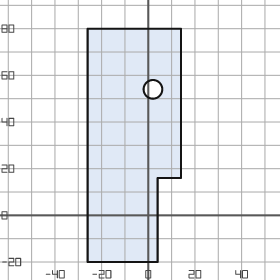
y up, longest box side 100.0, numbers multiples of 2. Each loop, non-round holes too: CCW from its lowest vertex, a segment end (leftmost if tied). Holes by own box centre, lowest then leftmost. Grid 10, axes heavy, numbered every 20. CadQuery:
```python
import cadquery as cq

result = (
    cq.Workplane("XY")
    .moveTo(-26.0, -20.0)
    .lineTo(4.0, -20.0)
    .lineTo(4.0, 16.0)
    .lineTo(14.0, 16.0)
    .lineTo(14.0, 80.0)
    .lineTo(-26.0, 80.0)
    .close()
    .moveTo(2.0, 54.0)
    .circle(4.0)
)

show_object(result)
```